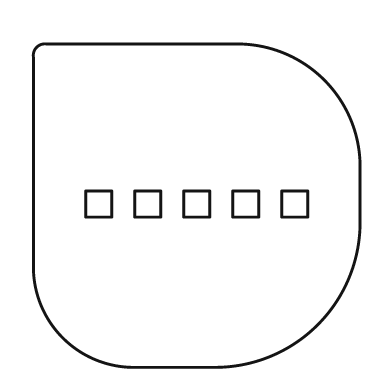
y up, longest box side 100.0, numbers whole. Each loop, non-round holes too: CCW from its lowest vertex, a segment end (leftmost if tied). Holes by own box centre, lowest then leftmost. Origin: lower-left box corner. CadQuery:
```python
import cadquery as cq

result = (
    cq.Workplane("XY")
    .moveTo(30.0, 0.0)
    .lineTo(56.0, 0.0)
    .threePointArc((87.0, 13.0), (100.0, 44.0))
    .lineTo(100.0, 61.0)
    .threePointArc((89.0, 88.0), (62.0, 99.0))
    .lineTo(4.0, 99.0)
    .threePointArc((1.0, 98.0), (0.0, 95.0))
    .lineTo(0.0, 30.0)
    .threePointArc((9.0, 9.0), (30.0, 0.0))
    .close()
    .moveTo(16.0, 46.0)
    .lineTo(24.0, 46.0)
    .lineTo(24.0, 54.0)
    .lineTo(16.0, 54.0)
    .close()
    .moveTo(31.0, 46.0)
    .lineTo(39.0, 46.0)
    .lineTo(39.0, 54.0)
    .lineTo(31.0, 54.0)
    .close()
    .moveTo(46.0, 46.0)
    .lineTo(54.0, 46.0)
    .lineTo(54.0, 54.0)
    .lineTo(46.0, 54.0)
    .close()
    .moveTo(61.0, 46.0)
    .lineTo(69.0, 46.0)
    .lineTo(69.0, 54.0)
    .lineTo(61.0, 54.0)
    .close()
    .moveTo(76.0, 46.0)
    .lineTo(84.0, 46.0)
    .lineTo(84.0, 54.0)
    .lineTo(76.0, 54.0)
    .close()
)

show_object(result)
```